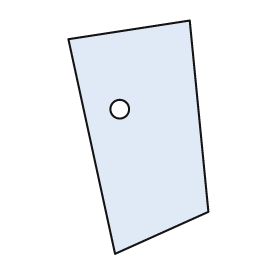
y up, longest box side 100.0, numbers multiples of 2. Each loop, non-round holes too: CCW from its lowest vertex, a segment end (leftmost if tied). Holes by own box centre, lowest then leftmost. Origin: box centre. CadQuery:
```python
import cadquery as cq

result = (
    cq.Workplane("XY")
    .moveTo(-10.0, -50.0)
    .lineTo(30.0, -32.0)
    .lineTo(22.0, 50.0)
    .lineTo(-30.0, 42.0)
    .close()
    .moveTo(-8.0, 12.0)
    .circle(4.0)
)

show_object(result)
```